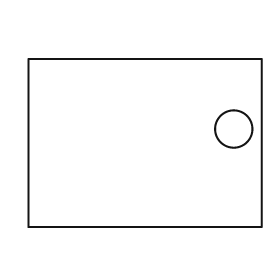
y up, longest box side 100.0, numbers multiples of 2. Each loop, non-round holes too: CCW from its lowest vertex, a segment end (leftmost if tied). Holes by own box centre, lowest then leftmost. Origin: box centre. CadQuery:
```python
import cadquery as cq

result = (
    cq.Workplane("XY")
    .moveTo(-50.0, -36.0)
    .lineTo(50.0, -36.0)
    .lineTo(50.0, 36.0)
    .lineTo(-50.0, 36.0)
    .close()
    .moveTo(38.0, 6.0)
    .circle(8.0)
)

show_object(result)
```